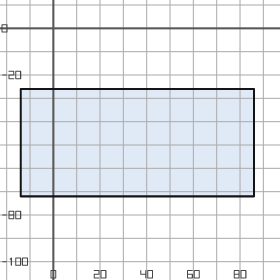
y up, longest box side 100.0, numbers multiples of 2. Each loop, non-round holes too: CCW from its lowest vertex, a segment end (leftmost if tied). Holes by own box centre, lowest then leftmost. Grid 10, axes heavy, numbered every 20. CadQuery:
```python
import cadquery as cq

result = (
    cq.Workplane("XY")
    .moveTo(-14.0, -72.0)
    .lineTo(86.0, -72.0)
    .lineTo(86.0, -26.0)
    .lineTo(-14.0, -26.0)
    .close()
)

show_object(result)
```